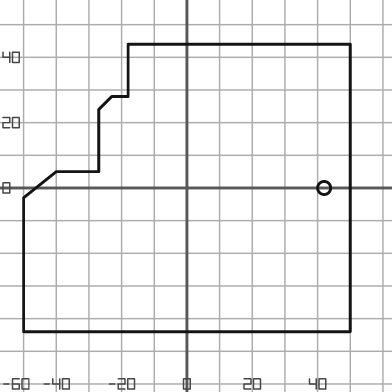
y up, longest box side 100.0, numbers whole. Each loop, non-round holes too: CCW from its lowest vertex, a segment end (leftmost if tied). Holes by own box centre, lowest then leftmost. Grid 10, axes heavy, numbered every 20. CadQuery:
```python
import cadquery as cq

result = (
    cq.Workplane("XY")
    .moveTo(-50.0, -44.0)
    .lineTo(50.0, -44.0)
    .lineTo(50.0, 44.0)
    .lineTo(-18.0, 44.0)
    .lineTo(-18.0, 28.0)
    .lineTo(-23.0, 28.0)
    .lineTo(-27.0, 24.0)
    .lineTo(-27.0, 5.0)
    .lineTo(-40.0, 5.0)
    .lineTo(-50.0, -3.0)
    .close()
    .moveTo(42.0, 0.0)
    .circle(2.0)
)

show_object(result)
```